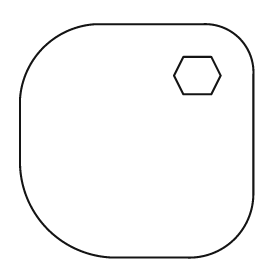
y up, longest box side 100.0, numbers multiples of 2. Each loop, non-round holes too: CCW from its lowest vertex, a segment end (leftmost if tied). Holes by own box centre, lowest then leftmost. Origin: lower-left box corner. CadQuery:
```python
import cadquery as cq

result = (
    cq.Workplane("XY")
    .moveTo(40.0, 0.0)
    .lineTo(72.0, 0.0)
    .threePointArc((92.0, 8.0), (100.0, 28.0))
    .lineTo(100.0, 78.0)
    .threePointArc((94.0, 94.0), (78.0, 100.0))
    .lineTo(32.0, 100.0)
    .threePointArc((10.0, 90.0), (0.0, 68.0))
    .lineTo(0.0, 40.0)
    .threePointArc((12.0, 12.0), (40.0, 0.0))
    .close()
    .moveTo(70.0, 70.0)
    .lineTo(82.0, 70.0)
    .lineTo(86.0, 78.0)
    .lineTo(82.0, 86.0)
    .lineTo(70.0, 86.0)
    .lineTo(66.0, 78.0)
    .close()
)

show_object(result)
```